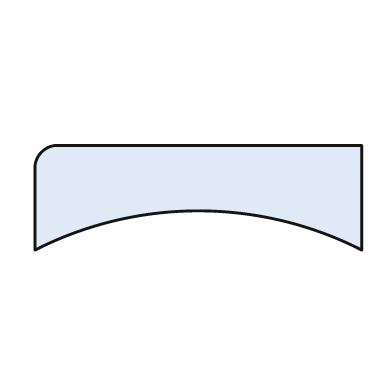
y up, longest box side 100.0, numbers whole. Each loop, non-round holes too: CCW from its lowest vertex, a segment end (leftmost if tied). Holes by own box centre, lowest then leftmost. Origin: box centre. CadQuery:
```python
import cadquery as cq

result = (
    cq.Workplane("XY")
    .moveTo(-50.0, -16.0)
    .threePointArc((0.0, -4.0), (50.0, -16.0))
    .lineTo(50.0, 16.0)
    .lineTo(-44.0, 16.0)
    .threePointArc((-48.0, 14.0), (-50.0, 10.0))
    .close()
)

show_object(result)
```